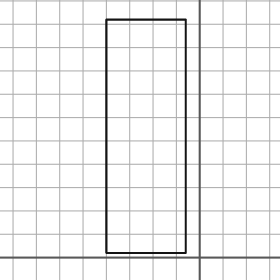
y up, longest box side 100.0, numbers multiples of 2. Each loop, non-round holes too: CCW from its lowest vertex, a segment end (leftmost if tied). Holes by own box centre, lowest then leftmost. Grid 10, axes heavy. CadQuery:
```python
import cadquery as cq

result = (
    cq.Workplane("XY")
    .moveTo(-40.0, 2.0)
    .lineTo(-6.0, 2.0)
    .lineTo(-6.0, 102.0)
    .lineTo(-40.0, 102.0)
    .close()
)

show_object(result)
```